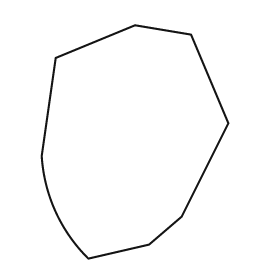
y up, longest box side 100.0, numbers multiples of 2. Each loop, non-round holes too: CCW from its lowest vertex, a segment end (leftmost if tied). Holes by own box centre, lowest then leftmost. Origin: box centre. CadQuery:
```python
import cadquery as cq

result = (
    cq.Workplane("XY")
    .moveTo(-20.0, -50.0)
    .lineTo(6.0, -44.0)
    .lineTo(20.0, -32.0)
    .lineTo(40.0, 8.0)
    .lineTo(24.0, 46.0)
    .lineTo(0.0, 50.0)
    .lineTo(-34.0, 36.0)
    .lineTo(-40.0, -6.0)
    .threePointArc((-34.0, -30.0), (-20.0, -50.0))
    .close()
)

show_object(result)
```